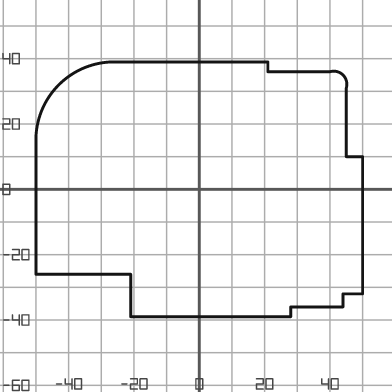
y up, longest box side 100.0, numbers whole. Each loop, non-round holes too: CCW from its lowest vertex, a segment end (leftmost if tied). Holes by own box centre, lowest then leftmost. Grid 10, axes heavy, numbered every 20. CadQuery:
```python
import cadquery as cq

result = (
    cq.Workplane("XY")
    .moveTo(-21.0, -39.0)
    .lineTo(28.0, -39.0)
    .lineTo(28.0, -36.0)
    .lineTo(44.0, -36.0)
    .lineTo(44.0, -32.0)
    .lineTo(50.0, -32.0)
    .lineTo(50.0, 10.0)
    .lineTo(45.0, 10.0)
    .lineTo(45.0, 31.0)
    .threePointArc((44.0, 35.0), (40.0, 36.0))
    .lineTo(21.0, 36.0)
    .lineTo(21.0, 39.0)
    .lineTo(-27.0, 39.0)
    .threePointArc((-43.0, 32.0), (-50.0, 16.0))
    .lineTo(-50.0, -26.0)
    .lineTo(-21.0, -26.0)
    .close()
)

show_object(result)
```